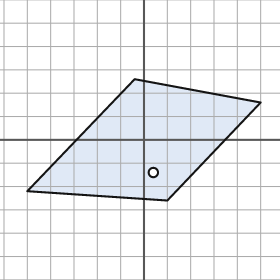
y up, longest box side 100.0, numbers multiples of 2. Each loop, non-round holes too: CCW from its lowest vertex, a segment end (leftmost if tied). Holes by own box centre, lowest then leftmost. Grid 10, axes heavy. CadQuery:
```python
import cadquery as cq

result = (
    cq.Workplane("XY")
    .moveTo(10.0, -26.0)
    .lineTo(50.0, 16.0)
    .lineTo(-4.0, 26.0)
    .lineTo(-50.0, -22.0)
    .close()
    .moveTo(4.0, -14.0)
    .circle(2.0)
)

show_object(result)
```